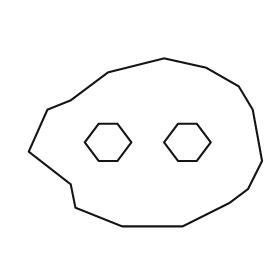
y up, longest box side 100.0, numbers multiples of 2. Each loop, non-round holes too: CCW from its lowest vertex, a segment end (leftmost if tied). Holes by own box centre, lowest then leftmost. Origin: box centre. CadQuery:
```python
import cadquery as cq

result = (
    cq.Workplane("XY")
    .moveTo(-10.0, -36.0)
    .lineTo(16.0, -36.0)
    .lineTo(36.0, -26.0)
    .lineTo(44.0, -20.0)
    .lineTo(50.0, -8.0)
    .lineTo(46.0, 14.0)
    .lineTo(40.0, 24.0)
    .lineTo(26.0, 32.0)
    .lineTo(8.0, 36.0)
    .lineTo(-16.0, 30.0)
    .lineTo(-32.0, 18.0)
    .lineTo(-42.0, 14.0)
    .lineTo(-50.0, -4.0)
    .lineTo(-32.0, -18.0)
    .lineTo(-30.0, -28.0)
    .close()
    .moveTo(-20.0, -8.0)
    .lineTo(-12.0, -8.0)
    .lineTo(-6.0, 0.0)
    .lineTo(-12.0, 8.0)
    .lineTo(-20.0, 8.0)
    .lineTo(-26.0, 0.0)
    .close()
    .moveTo(14.0, -8.0)
    .lineTo(22.0, -8.0)
    .lineTo(28.0, 0.0)
    .lineTo(22.0, 8.0)
    .lineTo(14.0, 8.0)
    .lineTo(8.0, 0.0)
    .close()
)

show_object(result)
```